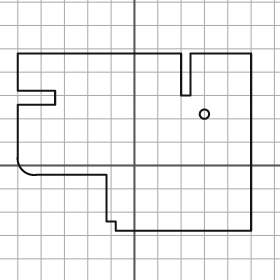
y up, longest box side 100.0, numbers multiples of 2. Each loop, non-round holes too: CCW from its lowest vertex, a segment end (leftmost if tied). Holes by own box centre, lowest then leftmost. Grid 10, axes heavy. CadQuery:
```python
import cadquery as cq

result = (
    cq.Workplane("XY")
    .moveTo(-8.0, -28.0)
    .lineTo(50.0, -28.0)
    .lineTo(50.0, 48.0)
    .lineTo(24.0, 48.0)
    .lineTo(24.0, 30.0)
    .lineTo(20.0, 30.0)
    .lineTo(20.0, 48.0)
    .lineTo(-50.0, 48.0)
    .lineTo(-50.0, 32.0)
    .lineTo(-34.0, 32.0)
    .lineTo(-34.0, 26.0)
    .lineTo(-50.0, 26.0)
    .lineTo(-50.0, 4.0)
    .threePointArc((-48.0, -2.0), (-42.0, -4.0))
    .lineTo(-12.0, -4.0)
    .lineTo(-12.0, -24.0)
    .lineTo(-8.0, -24.0)
    .close()
    .moveTo(30.0, 22.0)
    .circle(2.0)
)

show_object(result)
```